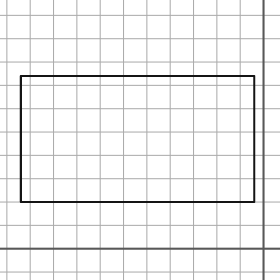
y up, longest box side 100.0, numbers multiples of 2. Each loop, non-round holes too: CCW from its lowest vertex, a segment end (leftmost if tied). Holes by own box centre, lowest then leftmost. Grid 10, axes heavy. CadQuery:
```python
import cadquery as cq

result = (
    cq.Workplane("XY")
    .moveTo(-104.0, 20.0)
    .lineTo(-4.0, 20.0)
    .lineTo(-4.0, 74.0)
    .lineTo(-104.0, 74.0)
    .close()
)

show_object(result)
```